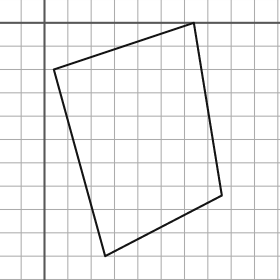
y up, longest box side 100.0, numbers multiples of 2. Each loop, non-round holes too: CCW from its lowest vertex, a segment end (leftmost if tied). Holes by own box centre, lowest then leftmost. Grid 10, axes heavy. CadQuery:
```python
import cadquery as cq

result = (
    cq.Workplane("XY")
    .moveTo(26.0, -100.0)
    .lineTo(76.0, -74.0)
    .lineTo(64.0, 0.0)
    .lineTo(4.0, -20.0)
    .close()
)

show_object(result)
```